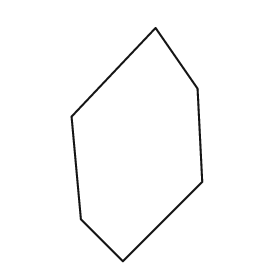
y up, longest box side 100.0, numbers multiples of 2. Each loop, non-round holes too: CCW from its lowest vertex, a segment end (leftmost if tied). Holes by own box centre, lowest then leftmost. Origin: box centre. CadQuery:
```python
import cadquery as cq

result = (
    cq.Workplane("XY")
    .moveTo(-6.0, -50.0)
    .lineTo(28.0, -16.0)
    .lineTo(26.0, 24.0)
    .lineTo(8.0, 50.0)
    .lineTo(-28.0, 12.0)
    .lineTo(-24.0, -32.0)
    .close()
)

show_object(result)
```